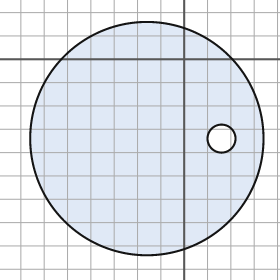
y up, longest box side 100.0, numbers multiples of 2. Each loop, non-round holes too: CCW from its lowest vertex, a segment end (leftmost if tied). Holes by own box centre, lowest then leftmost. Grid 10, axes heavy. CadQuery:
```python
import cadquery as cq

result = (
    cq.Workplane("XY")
    .moveTo(-16.0, -34.0)
    .circle(50.0)
    .moveTo(16.0, -34.0)
    .circle(6.0)
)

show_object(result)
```